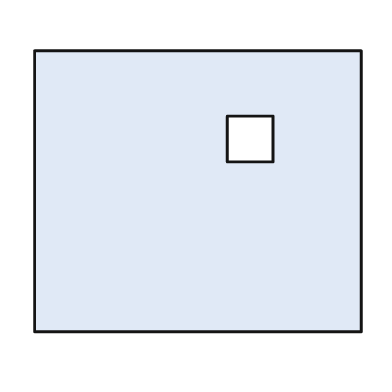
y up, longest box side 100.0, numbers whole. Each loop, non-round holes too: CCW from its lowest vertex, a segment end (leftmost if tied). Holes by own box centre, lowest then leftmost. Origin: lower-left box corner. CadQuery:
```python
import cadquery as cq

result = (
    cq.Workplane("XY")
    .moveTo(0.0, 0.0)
    .lineTo(100.0, 0.0)
    .lineTo(100.0, 86.0)
    .lineTo(0.0, 86.0)
    .close()
    .moveTo(59.0, 52.0)
    .lineTo(73.0, 52.0)
    .lineTo(73.0, 66.0)
    .lineTo(59.0, 66.0)
    .close()
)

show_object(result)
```